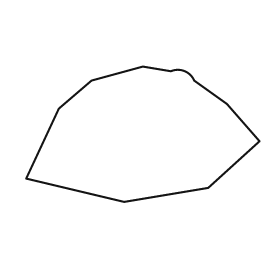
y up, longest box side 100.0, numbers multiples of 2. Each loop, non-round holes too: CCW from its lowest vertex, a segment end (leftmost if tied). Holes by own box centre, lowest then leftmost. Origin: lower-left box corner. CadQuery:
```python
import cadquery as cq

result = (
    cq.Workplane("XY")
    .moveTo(42.0, 0.0)
    .lineTo(78.0, 6.0)
    .lineTo(100.0, 26.0)
    .lineTo(86.0, 42.0)
    .lineTo(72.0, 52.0)
    .threePointArc((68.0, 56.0), (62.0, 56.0))
    .lineTo(50.0, 58.0)
    .lineTo(28.0, 52.0)
    .lineTo(14.0, 40.0)
    .lineTo(0.0, 10.0)
    .close()
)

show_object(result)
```